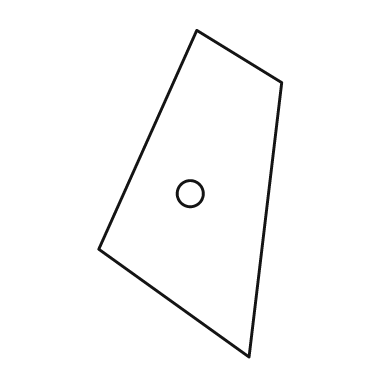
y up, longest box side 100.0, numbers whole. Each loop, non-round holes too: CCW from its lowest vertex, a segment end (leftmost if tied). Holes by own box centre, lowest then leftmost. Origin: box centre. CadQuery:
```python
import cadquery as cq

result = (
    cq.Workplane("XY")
    .moveTo(18.0, -50.0)
    .lineTo(28.0, 34.0)
    .lineTo(2.0, 50.0)
    .lineTo(-28.0, -17.0)
    .close()
    .moveTo(0.0, 0.0)
    .circle(4.0)
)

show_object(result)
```